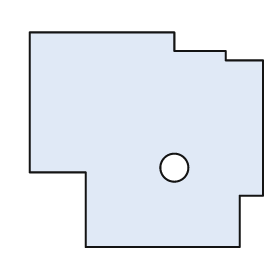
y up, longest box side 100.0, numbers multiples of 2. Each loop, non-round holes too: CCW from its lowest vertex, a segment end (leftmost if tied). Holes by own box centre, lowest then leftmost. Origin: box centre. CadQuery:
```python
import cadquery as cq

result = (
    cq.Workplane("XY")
    .moveTo(-26.0, -46.0)
    .lineTo(40.0, -46.0)
    .lineTo(40.0, -24.0)
    .lineTo(50.0, -24.0)
    .lineTo(50.0, 34.0)
    .lineTo(34.0, 34.0)
    .lineTo(34.0, 38.0)
    .lineTo(12.0, 38.0)
    .lineTo(12.0, 46.0)
    .lineTo(-50.0, 46.0)
    .lineTo(-50.0, -14.0)
    .lineTo(-26.0, -14.0)
    .close()
    .moveTo(12.0, -12.0)
    .circle(6.0)
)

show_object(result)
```